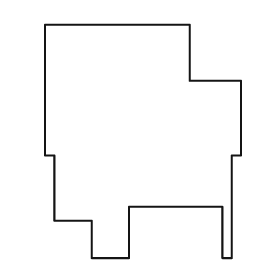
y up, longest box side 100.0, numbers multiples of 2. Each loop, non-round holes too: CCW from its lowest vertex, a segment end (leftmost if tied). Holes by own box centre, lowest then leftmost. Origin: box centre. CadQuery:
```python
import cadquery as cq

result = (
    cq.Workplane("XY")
    .moveTo(-22.0, -50.0)
    .lineTo(-6.0, -50.0)
    .lineTo(-6.0, -28.0)
    .lineTo(34.0, -28.0)
    .lineTo(34.0, -50.0)
    .lineTo(38.0, -50.0)
    .lineTo(38.0, -6.0)
    .lineTo(42.0, -6.0)
    .lineTo(42.0, 26.0)
    .lineTo(20.0, 26.0)
    .lineTo(20.0, 50.0)
    .lineTo(-42.0, 50.0)
    .lineTo(-42.0, -6.0)
    .lineTo(-38.0, -6.0)
    .lineTo(-38.0, -34.0)
    .lineTo(-22.0, -34.0)
    .close()
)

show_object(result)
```